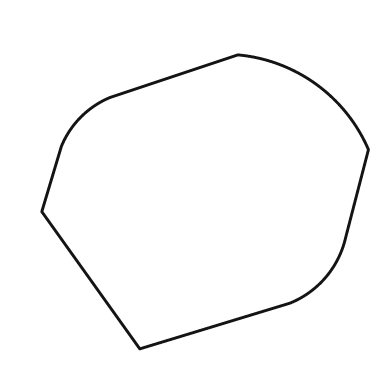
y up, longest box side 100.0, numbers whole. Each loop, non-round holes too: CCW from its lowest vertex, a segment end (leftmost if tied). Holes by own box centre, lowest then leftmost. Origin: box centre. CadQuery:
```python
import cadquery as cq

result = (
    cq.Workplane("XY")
    .moveTo(-20.0, -45.0)
    .lineTo(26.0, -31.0)
    .threePointArc((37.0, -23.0), (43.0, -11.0))
    .lineTo(50.0, 16.0)
    .threePointArc((34.0, 36.0), (10.0, 45.0))
    .lineTo(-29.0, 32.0)
    .threePointArc((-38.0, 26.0), (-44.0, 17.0))
    .lineTo(-50.0, -3.0)
    .close()
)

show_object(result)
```